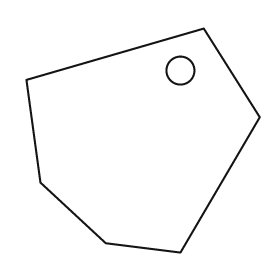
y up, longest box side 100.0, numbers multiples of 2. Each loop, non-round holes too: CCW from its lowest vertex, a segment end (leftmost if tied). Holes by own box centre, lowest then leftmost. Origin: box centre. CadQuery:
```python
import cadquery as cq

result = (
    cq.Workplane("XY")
    .moveTo(16.0, -48.0)
    .lineTo(50.0, 10.0)
    .lineTo(26.0, 48.0)
    .lineTo(-50.0, 26.0)
    .lineTo(-44.0, -18.0)
    .lineTo(-16.0, -44.0)
    .close()
    .moveTo(16.0, 30.0)
    .circle(6.0)
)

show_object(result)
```